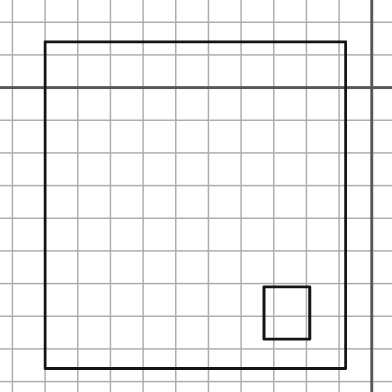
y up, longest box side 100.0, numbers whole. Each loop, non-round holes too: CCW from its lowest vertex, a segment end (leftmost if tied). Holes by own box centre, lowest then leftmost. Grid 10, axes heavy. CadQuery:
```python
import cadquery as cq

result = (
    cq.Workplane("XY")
    .moveTo(-100.0, -86.0)
    .lineTo(-8.0, -86.0)
    .lineTo(-8.0, 14.0)
    .lineTo(-100.0, 14.0)
    .close()
    .moveTo(-33.0, -77.0)
    .lineTo(-19.0, -77.0)
    .lineTo(-19.0, -61.0)
    .lineTo(-33.0, -61.0)
    .close()
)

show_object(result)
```